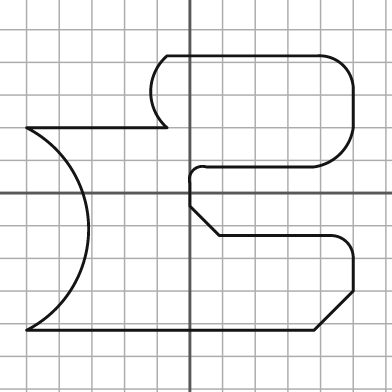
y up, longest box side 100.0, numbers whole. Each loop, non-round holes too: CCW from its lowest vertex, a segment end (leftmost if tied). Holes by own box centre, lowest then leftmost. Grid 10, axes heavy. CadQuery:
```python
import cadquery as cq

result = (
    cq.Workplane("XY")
    .moveTo(-50.0, -42.0)
    .lineTo(38.0, -42.0)
    .lineTo(50.0, -30.0)
    .lineTo(50.0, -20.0)
    .threePointArc((48.0, -15.0), (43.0, -13.0))
    .lineTo(9.0, -13.0)
    .lineTo(0.0, -4.0)
    .lineTo(0.0, 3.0)
    .threePointArc((1.0, 7.0), (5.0, 8.0))
    .lineTo(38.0, 8.0)
    .threePointArc((46.0, 12.0), (50.0, 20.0))
    .lineTo(50.0, 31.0)
    .threePointArc((47.0, 39.0), (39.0, 42.0))
    .lineTo(-7.0, 42.0)
    .threePointArc((-12.0, 31.0), (-7.0, 20.0))
    .lineTo(-50.0, 20.0)
    .threePointArc((-31.0, -11.0), (-50.0, -42.0))
    .close()
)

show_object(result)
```